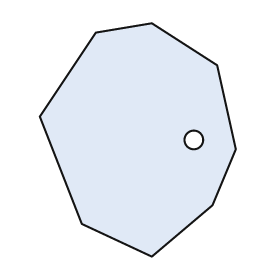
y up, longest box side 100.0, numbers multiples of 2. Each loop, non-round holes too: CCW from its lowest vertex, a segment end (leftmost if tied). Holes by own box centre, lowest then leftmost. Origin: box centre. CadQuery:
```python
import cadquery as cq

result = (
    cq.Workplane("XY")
    .moveTo(6.0, -50.0)
    .lineTo(32.0, -28.0)
    .lineTo(42.0, -4.0)
    .lineTo(34.0, 32.0)
    .lineTo(6.0, 50.0)
    .lineTo(-18.0, 46.0)
    .lineTo(-42.0, 10.0)
    .lineTo(-24.0, -36.0)
    .close()
    .moveTo(24.0, 0.0)
    .circle(4.0)
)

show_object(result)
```